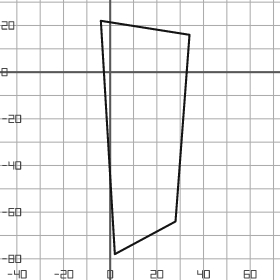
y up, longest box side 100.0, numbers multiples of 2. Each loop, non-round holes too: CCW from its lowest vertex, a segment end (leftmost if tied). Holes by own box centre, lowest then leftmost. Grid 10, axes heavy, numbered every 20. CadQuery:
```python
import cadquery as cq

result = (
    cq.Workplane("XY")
    .moveTo(2.0, -78.0)
    .lineTo(28.0, -64.0)
    .lineTo(34.0, 16.0)
    .lineTo(-4.0, 22.0)
    .close()
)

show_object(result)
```